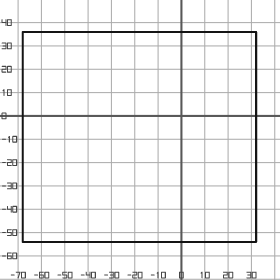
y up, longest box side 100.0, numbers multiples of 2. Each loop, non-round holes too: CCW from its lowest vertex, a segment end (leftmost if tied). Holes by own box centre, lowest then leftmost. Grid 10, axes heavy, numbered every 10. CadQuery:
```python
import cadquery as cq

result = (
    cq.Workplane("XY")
    .moveTo(-68.0, -54.0)
    .lineTo(32.0, -54.0)
    .lineTo(32.0, 36.0)
    .lineTo(-68.0, 36.0)
    .close()
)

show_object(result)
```